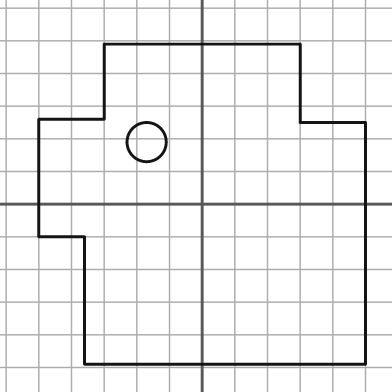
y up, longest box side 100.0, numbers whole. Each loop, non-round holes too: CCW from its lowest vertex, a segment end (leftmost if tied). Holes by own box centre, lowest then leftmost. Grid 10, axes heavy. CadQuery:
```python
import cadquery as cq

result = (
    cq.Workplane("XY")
    .moveTo(-36.0, -49.0)
    .lineTo(50.0, -49.0)
    .lineTo(50.0, 25.0)
    .lineTo(30.0, 25.0)
    .lineTo(30.0, 49.0)
    .lineTo(-30.0, 49.0)
    .lineTo(-30.0, 26.0)
    .lineTo(-50.0, 26.0)
    .lineTo(-50.0, -10.0)
    .lineTo(-36.0, -10.0)
    .close()
    .moveTo(-17.0, 19.0)
    .circle(6.0)
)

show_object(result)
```